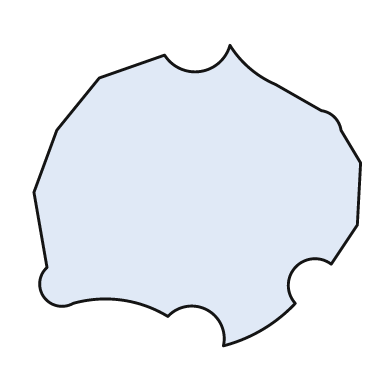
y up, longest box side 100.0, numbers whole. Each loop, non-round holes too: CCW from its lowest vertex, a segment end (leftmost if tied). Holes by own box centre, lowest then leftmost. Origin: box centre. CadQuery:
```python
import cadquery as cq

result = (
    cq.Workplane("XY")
    .moveTo(8.0, -46.0)
    .threePointArc((20.0, -41.0), (30.0, -33.0))
    .threePointArc((30.0, -22.0), (41.0, -21.0))
    .lineTo(49.0, -9.0)
    .lineTo(50.0, 10.0)
    .lineTo(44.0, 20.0)
    .threePointArc((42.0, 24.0), (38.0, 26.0))
    .lineTo(24.0, 34.0)
    .threePointArc((16.0, 39.0), (10.0, 46.0))
    .threePointArc((1.0, 38.0), (-10.0, 43.0))
    .lineTo(-30.0, 36.0)
    .lineTo(-43.0, 20.0)
    .lineTo(-50.0, 1.0)
    .lineTo(-46.0, -22.0)
    .threePointArc((-47.0, -31.0), (-38.0, -33.0))
    .threePointArc((-23.0, -32.0), (-9.0, -37.0))
    .threePointArc((3.0, -35.0), (8.0, -46.0))
    .close()
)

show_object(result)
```